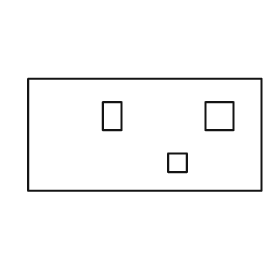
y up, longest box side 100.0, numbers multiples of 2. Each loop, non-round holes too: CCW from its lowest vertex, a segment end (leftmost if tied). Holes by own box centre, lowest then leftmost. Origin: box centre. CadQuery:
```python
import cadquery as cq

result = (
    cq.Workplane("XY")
    .moveTo(-50.0, -24.0)
    .lineTo(50.0, -24.0)
    .lineTo(50.0, 24.0)
    .lineTo(-50.0, 24.0)
    .close()
    .moveTo(10.0, -16.0)
    .lineTo(18.0, -16.0)
    .lineTo(18.0, -8.0)
    .lineTo(10.0, -8.0)
    .close()
    .moveTo(-18.0, 2.0)
    .lineTo(-10.0, 2.0)
    .lineTo(-10.0, 14.0)
    .lineTo(-18.0, 14.0)
    .close()
    .moveTo(26.0, 2.0)
    .lineTo(38.0, 2.0)
    .lineTo(38.0, 14.0)
    .lineTo(26.0, 14.0)
    .close()
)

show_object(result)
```